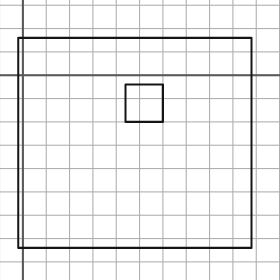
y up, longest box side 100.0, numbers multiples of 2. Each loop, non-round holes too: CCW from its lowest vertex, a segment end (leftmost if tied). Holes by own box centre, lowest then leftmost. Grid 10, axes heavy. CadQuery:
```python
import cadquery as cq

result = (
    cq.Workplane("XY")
    .moveTo(-2.0, -74.0)
    .lineTo(98.0, -74.0)
    .lineTo(98.0, 16.0)
    .lineTo(-2.0, 16.0)
    .close()
    .moveTo(44.0, -20.0)
    .lineTo(60.0, -20.0)
    .lineTo(60.0, -4.0)
    .lineTo(44.0, -4.0)
    .close()
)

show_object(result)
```